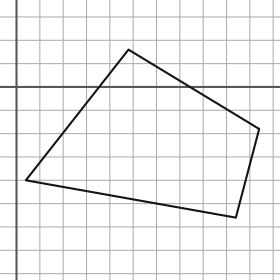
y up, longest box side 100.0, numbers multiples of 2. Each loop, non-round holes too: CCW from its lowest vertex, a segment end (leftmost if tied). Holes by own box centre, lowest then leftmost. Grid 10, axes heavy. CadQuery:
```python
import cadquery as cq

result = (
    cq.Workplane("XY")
    .moveTo(94.0, -56.0)
    .lineTo(104.0, -18.0)
    .lineTo(48.0, 16.0)
    .lineTo(4.0, -40.0)
    .close()
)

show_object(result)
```